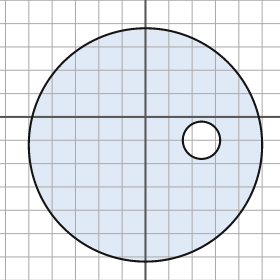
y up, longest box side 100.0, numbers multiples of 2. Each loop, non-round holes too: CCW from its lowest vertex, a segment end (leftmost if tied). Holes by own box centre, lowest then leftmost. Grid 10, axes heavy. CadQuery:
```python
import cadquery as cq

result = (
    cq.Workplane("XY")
    .moveTo(0.0, -12.0)
    .circle(50.0)
    .moveTo(24.0, -10.0)
    .circle(8.0)
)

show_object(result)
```